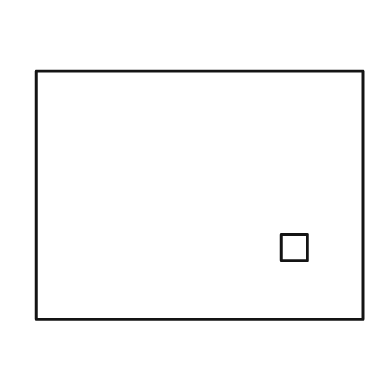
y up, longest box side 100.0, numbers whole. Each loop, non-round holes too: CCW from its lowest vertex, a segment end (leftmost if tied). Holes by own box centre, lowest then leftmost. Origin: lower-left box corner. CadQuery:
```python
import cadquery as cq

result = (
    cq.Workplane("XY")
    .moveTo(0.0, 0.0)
    .lineTo(100.0, 0.0)
    .lineTo(100.0, 76.0)
    .lineTo(0.0, 76.0)
    .close()
    .moveTo(75.0, 18.0)
    .lineTo(83.0, 18.0)
    .lineTo(83.0, 26.0)
    .lineTo(75.0, 26.0)
    .close()
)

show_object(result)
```